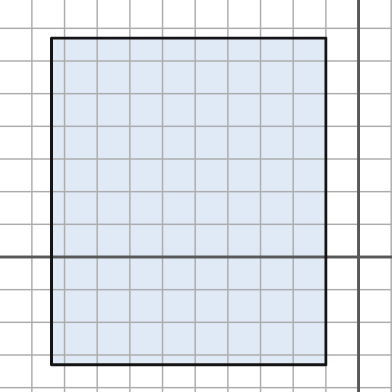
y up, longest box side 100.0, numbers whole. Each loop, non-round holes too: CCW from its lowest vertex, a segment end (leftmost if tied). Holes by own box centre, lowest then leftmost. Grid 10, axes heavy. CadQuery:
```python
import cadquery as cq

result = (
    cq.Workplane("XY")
    .moveTo(-94.0, -33.0)
    .lineTo(-10.0, -33.0)
    .lineTo(-10.0, 67.0)
    .lineTo(-94.0, 67.0)
    .close()
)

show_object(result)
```